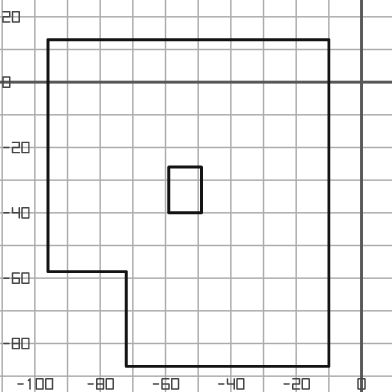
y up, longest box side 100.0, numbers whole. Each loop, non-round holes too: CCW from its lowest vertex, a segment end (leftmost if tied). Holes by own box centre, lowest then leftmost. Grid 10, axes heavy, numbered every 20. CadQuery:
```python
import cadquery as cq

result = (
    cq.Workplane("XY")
    .moveTo(-72.0, -87.0)
    .lineTo(-10.0, -87.0)
    .lineTo(-10.0, 13.0)
    .lineTo(-96.0, 13.0)
    .lineTo(-96.0, -58.0)
    .lineTo(-72.0, -58.0)
    .close()
    .moveTo(-59.0, -40.0)
    .lineTo(-49.0, -40.0)
    .lineTo(-49.0, -26.0)
    .lineTo(-59.0, -26.0)
    .close()
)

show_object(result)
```